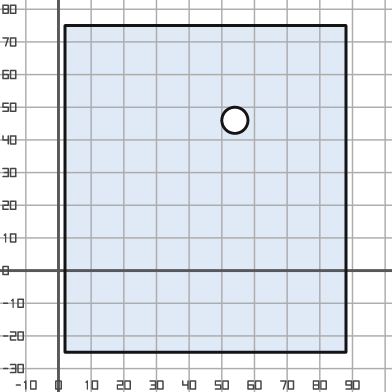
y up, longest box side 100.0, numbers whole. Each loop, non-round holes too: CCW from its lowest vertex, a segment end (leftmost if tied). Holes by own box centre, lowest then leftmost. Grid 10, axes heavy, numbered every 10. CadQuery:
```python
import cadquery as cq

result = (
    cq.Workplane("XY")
    .moveTo(2.0, -25.0)
    .lineTo(88.0, -25.0)
    .lineTo(88.0, 75.0)
    .lineTo(2.0, 75.0)
    .close()
    .moveTo(54.0, 46.0)
    .circle(4.0)
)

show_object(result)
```